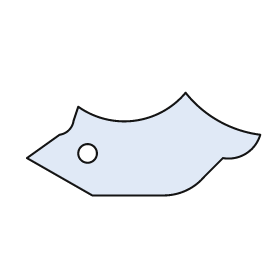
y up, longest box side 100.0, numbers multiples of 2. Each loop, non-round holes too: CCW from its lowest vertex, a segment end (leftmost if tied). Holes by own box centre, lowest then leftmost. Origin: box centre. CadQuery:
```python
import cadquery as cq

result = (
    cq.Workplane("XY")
    .moveTo(-22.0, -22.0)
    .lineTo(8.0, -22.0)
    .threePointArc((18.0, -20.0), (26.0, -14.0))
    .lineTo(34.0, -6.0)
    .threePointArc((44.0, -4.0), (50.0, 4.0))
    .threePointArc((32.0, 10.0), (18.0, 22.0))
    .threePointArc((-4.0, 10.0), (-28.0, 16.0))
    .lineTo(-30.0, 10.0)
    .threePointArc((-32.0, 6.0), (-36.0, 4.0))
    .lineTo(-50.0, -6.0)
    .close()
    .moveTo(-24.0, -4.0)
    .circle(4.0)
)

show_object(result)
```